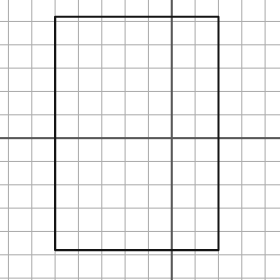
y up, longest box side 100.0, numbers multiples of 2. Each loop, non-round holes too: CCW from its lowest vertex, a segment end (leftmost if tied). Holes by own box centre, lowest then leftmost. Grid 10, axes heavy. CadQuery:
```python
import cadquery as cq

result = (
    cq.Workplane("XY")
    .moveTo(-50.0, -48.0)
    .lineTo(20.0, -48.0)
    .lineTo(20.0, 52.0)
    .lineTo(-50.0, 52.0)
    .close()
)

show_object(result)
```